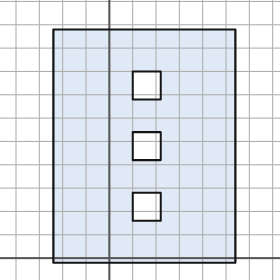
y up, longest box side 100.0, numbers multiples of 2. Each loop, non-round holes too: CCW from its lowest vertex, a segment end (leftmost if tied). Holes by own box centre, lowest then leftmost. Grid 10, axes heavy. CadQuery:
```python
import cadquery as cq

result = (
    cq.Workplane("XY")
    .moveTo(-24.0, -2.0)
    .lineTo(54.0, -2.0)
    .lineTo(54.0, 98.0)
    .lineTo(-24.0, 98.0)
    .close()
    .moveTo(10.0, 16.0)
    .lineTo(22.0, 16.0)
    .lineTo(22.0, 28.0)
    .lineTo(10.0, 28.0)
    .close()
    .moveTo(10.0, 42.0)
    .lineTo(22.0, 42.0)
    .lineTo(22.0, 54.0)
    .lineTo(10.0, 54.0)
    .close()
    .moveTo(10.0, 68.0)
    .lineTo(22.0, 68.0)
    .lineTo(22.0, 80.0)
    .lineTo(10.0, 80.0)
    .close()
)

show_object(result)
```